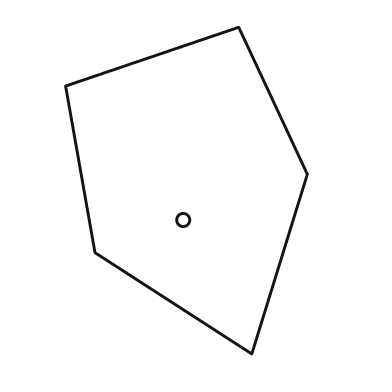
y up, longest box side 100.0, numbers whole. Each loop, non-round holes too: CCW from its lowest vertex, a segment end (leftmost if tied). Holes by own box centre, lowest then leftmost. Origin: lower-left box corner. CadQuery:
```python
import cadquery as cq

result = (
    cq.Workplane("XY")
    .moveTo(57.0, 0.0)
    .lineTo(74.0, 55.0)
    .lineTo(53.0, 100.0)
    .lineTo(0.0, 82.0)
    .lineTo(9.0, 31.0)
    .close()
    .moveTo(36.0, 41.0)
    .circle(2.0)
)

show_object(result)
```